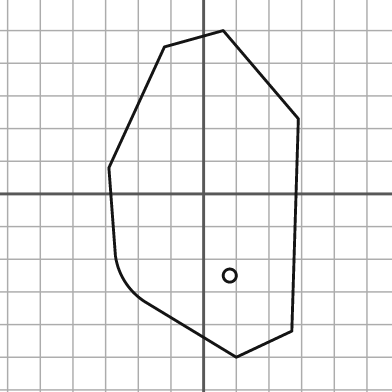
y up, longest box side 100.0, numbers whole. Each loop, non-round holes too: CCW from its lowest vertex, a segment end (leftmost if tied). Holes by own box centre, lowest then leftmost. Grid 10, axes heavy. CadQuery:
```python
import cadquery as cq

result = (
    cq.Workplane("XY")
    .moveTo(10.0, -50.0)
    .lineTo(27.0, -42.0)
    .lineTo(29.0, 23.0)
    .lineTo(6.0, 50.0)
    .lineTo(-12.0, 45.0)
    .lineTo(-29.0, 8.0)
    .lineTo(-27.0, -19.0)
    .threePointArc((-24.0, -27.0), (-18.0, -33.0))
    .close()
    .moveTo(8.0, -25.0)
    .circle(2.0)
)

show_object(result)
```